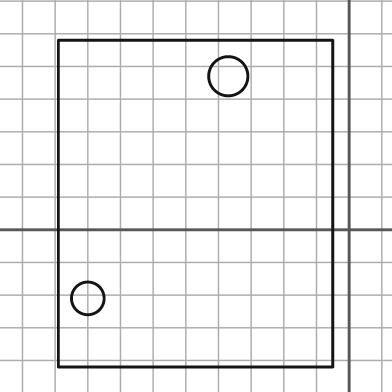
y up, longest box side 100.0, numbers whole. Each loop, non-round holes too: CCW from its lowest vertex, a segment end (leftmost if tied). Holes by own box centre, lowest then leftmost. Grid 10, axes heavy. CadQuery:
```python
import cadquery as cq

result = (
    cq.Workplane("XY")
    .moveTo(-89.0, -42.0)
    .lineTo(-5.0, -42.0)
    .lineTo(-5.0, 58.0)
    .lineTo(-89.0, 58.0)
    .close()
    .moveTo(-80.0, -21.0)
    .circle(5.0)
    .moveTo(-37.0, 47.0)
    .circle(6.0)
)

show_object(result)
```